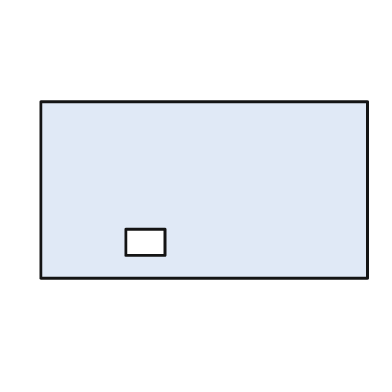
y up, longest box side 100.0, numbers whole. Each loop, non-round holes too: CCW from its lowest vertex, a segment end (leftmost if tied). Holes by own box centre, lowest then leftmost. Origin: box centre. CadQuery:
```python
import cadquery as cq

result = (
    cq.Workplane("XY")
    .moveTo(-50.0, -27.0)
    .lineTo(50.0, -27.0)
    .lineTo(50.0, 27.0)
    .lineTo(-50.0, 27.0)
    .close()
    .moveTo(-24.0, -20.0)
    .lineTo(-12.0, -20.0)
    .lineTo(-12.0, -12.0)
    .lineTo(-24.0, -12.0)
    .close()
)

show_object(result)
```